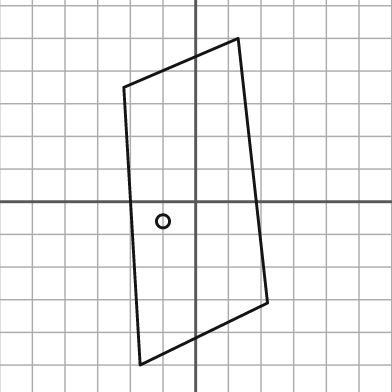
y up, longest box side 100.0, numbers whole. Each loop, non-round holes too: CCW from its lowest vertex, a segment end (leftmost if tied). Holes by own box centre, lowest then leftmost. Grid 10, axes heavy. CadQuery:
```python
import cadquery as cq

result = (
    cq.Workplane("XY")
    .moveTo(-17.0, -50.0)
    .lineTo(22.0, -31.0)
    .lineTo(13.0, 50.0)
    .lineTo(-22.0, 35.0)
    .close()
    .moveTo(-10.0, -6.0)
    .circle(2.0)
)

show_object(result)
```